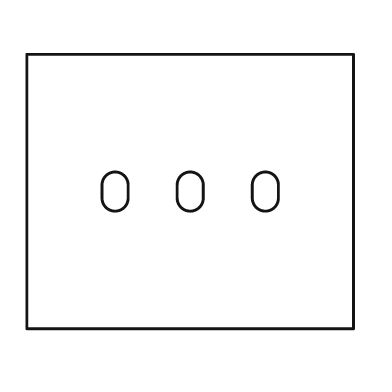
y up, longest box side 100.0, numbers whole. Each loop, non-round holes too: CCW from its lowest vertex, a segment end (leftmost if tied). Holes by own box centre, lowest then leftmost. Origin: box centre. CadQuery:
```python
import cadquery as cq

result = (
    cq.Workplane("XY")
    .moveTo(-50.0, -42.0)
    .lineTo(50.0, -42.0)
    .lineTo(50.0, 42.0)
    .lineTo(-50.0, 42.0)
    .close()
    .moveTo(-27.0, -2.0)
    .threePointArc((-23.0, -6.0), (-19.0, -2.0))
    .lineTo(-19.0, 2.0)
    .threePointArc((-23.0, 6.0), (-27.0, 2.0))
    .close()
    .moveTo(-4.0, -2.0)
    .threePointArc((0.0, -6.0), (4.0, -2.0))
    .lineTo(4.0, 2.0)
    .threePointArc((0.0, 6.0), (-4.0, 2.0))
    .close()
    .moveTo(19.0, -2.0)
    .threePointArc((23.0, -6.0), (27.0, -2.0))
    .lineTo(27.0, 2.0)
    .threePointArc((23.0, 6.0), (19.0, 2.0))
    .close()
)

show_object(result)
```